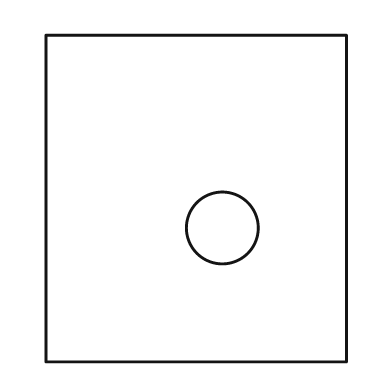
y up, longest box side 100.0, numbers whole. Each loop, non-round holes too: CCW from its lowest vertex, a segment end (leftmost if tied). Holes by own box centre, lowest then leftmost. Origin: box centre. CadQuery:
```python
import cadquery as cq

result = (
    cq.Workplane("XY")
    .moveTo(-46.0, -50.0)
    .lineTo(46.0, -50.0)
    .lineTo(46.0, 50.0)
    .lineTo(-46.0, 50.0)
    .close()
    .moveTo(8.0, -9.0)
    .circle(11.0)
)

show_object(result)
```